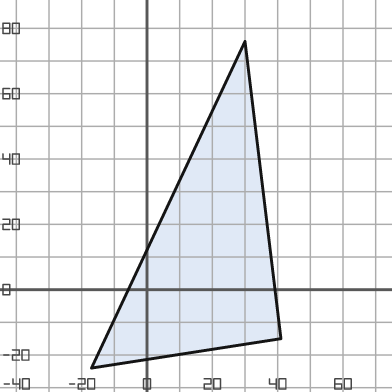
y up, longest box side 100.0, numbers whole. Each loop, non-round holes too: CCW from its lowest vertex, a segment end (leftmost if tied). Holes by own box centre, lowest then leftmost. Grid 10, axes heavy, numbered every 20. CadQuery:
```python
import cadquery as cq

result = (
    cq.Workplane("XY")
    .moveTo(-17.0, -24.0)
    .lineTo(41.0, -15.0)
    .lineTo(30.0, 76.0)
    .close()
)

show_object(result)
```